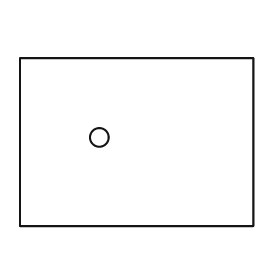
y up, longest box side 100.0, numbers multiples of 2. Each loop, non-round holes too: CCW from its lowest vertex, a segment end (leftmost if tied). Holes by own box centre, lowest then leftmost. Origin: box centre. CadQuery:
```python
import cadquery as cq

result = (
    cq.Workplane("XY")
    .moveTo(-50.0, -36.0)
    .lineTo(50.0, -36.0)
    .lineTo(50.0, 36.0)
    .lineTo(-50.0, 36.0)
    .close()
    .moveTo(-16.0, 2.0)
    .circle(4.0)
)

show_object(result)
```